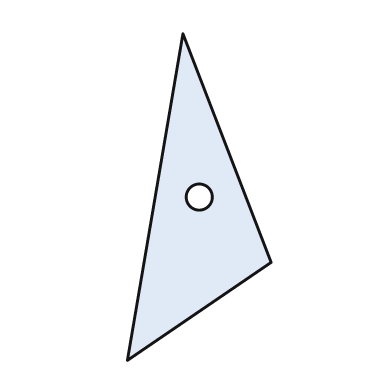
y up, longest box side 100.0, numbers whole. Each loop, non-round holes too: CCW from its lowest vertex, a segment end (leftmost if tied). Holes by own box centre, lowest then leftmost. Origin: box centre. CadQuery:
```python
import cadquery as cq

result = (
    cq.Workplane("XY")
    .moveTo(-22.0, -50.0)
    .lineTo(22.0, -20.0)
    .lineTo(-5.0, 50.0)
    .close()
    .moveTo(0.0, 0.0)
    .circle(4.0)
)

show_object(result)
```